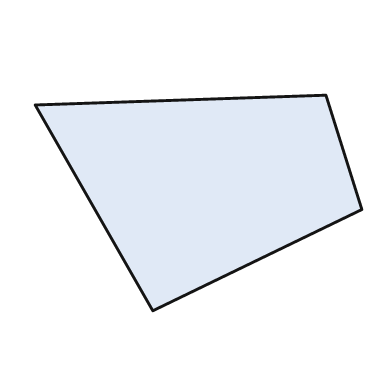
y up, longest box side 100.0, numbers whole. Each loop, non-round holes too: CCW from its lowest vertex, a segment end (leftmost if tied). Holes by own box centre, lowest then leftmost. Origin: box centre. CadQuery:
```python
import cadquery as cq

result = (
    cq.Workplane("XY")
    .moveTo(-14.0, -33.0)
    .lineTo(50.0, -2.0)
    .lineTo(39.0, 33.0)
    .lineTo(-50.0, 30.0)
    .close()
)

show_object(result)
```